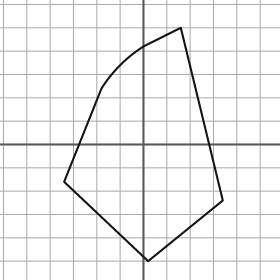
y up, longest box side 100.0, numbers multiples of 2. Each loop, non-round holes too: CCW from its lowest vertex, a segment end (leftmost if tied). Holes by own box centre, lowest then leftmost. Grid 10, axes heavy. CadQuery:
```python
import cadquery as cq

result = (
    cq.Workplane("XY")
    .moveTo(2.0, -50.0)
    .lineTo(34.0, -24.0)
    .lineTo(16.0, 50.0)
    .lineTo(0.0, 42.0)
    .threePointArc((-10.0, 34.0), (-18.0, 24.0))
    .lineTo(-34.0, -16.0)
    .close()
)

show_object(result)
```